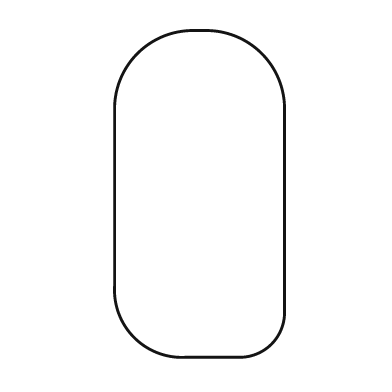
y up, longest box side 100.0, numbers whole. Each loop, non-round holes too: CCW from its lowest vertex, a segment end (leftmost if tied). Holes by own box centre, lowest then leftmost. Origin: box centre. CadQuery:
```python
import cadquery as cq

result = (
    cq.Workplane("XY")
    .moveTo(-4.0, -50.0)
    .lineTo(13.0, -50.0)
    .threePointArc((22.0, -46.0), (26.0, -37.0))
    .lineTo(26.0, 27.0)
    .threePointArc((19.0, 43.0), (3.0, 50.0))
    .lineTo(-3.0, 50.0)
    .threePointArc((-19.0, 43.0), (-26.0, 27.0))
    .lineTo(-26.0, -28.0)
    .threePointArc((-20.0, -44.0), (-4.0, -50.0))
    .close()
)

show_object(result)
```